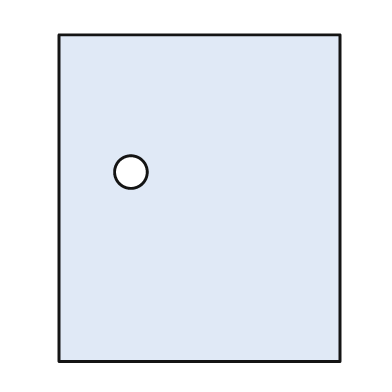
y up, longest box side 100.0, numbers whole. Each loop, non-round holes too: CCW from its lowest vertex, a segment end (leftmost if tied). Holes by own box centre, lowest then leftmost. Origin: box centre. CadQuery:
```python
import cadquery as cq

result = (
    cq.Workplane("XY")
    .moveTo(-43.0, -50.0)
    .lineTo(43.0, -50.0)
    .lineTo(43.0, 50.0)
    .lineTo(-43.0, 50.0)
    .close()
    .moveTo(-21.0, 8.0)
    .circle(5.0)
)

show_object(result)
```